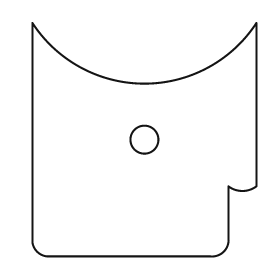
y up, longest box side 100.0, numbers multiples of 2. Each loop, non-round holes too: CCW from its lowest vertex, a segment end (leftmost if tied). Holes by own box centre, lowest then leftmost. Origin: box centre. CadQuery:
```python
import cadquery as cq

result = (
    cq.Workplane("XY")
    .moveTo(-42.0, -50.0)
    .lineTo(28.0, -50.0)
    .threePointArc((34.0, -48.0), (36.0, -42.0))
    .lineTo(36.0, -20.0)
    .threePointArc((42.0, -22.0), (48.0, -20.0))
    .lineTo(48.0, 50.0)
    .threePointArc((0.0, 24.0), (-48.0, 50.0))
    .lineTo(-48.0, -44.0)
    .threePointArc((-46.0, -48.0), (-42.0, -50.0))
    .close()
    .moveTo(0.0, 0.0)
    .circle(6.0)
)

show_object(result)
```